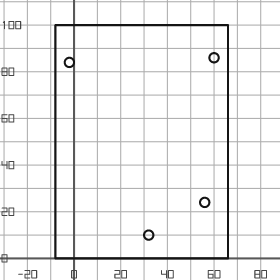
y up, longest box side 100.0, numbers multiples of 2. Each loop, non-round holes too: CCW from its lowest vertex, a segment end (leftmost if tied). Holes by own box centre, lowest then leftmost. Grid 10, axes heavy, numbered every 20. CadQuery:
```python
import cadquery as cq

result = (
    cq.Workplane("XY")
    .moveTo(-8.0, 0.0)
    .lineTo(66.0, 0.0)
    .lineTo(66.0, 100.0)
    .lineTo(-8.0, 100.0)
    .close()
    .moveTo(32.0, 10.0)
    .circle(2.0)
    .moveTo(56.0, 24.0)
    .circle(2.0)
    .moveTo(-2.0, 84.0)
    .circle(2.0)
    .moveTo(60.0, 86.0)
    .circle(2.0)
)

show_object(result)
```